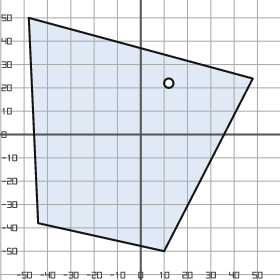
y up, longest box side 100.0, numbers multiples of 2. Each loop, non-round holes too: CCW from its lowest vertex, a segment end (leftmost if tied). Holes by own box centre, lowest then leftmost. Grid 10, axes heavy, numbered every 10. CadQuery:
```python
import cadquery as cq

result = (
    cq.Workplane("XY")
    .moveTo(10.0, -50.0)
    .lineTo(48.0, 24.0)
    .lineTo(-48.0, 50.0)
    .lineTo(-44.0, -38.0)
    .close()
    .moveTo(12.0, 22.0)
    .circle(2.0)
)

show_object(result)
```